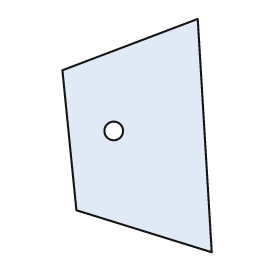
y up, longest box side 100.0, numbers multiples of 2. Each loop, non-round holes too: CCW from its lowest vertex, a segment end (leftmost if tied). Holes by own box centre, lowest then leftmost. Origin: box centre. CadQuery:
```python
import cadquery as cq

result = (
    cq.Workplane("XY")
    .moveTo(32.0, -50.0)
    .lineTo(26.0, 50.0)
    .lineTo(-32.0, 28.0)
    .lineTo(-26.0, -32.0)
    .close()
    .moveTo(-10.0, 2.0)
    .circle(4.0)
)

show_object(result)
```